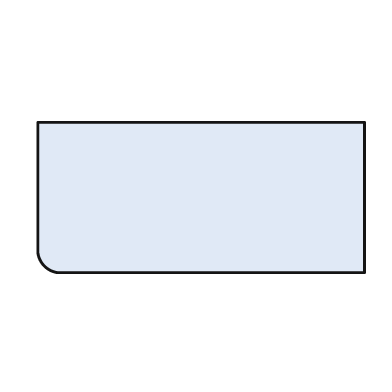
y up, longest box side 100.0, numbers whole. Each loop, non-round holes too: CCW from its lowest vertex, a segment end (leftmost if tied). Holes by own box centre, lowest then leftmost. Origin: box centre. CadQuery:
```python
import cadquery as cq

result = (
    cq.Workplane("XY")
    .moveTo(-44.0, -23.0)
    .lineTo(50.0, -23.0)
    .lineTo(50.0, 23.0)
    .lineTo(-50.0, 23.0)
    .lineTo(-50.0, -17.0)
    .threePointArc((-48.0, -21.0), (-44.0, -23.0))
    .close()
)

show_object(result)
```